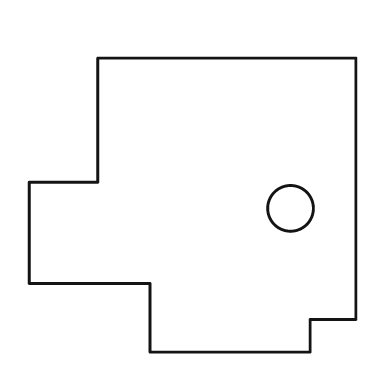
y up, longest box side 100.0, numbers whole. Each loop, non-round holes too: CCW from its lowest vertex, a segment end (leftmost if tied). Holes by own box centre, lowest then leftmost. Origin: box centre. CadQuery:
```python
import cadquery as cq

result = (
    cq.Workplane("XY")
    .moveTo(-13.0, -45.0)
    .lineTo(36.0, -45.0)
    .lineTo(36.0, -35.0)
    .lineTo(50.0, -35.0)
    .lineTo(50.0, 45.0)
    .lineTo(-29.0, 45.0)
    .lineTo(-29.0, 7.0)
    .lineTo(-50.0, 7.0)
    .lineTo(-50.0, -24.0)
    .lineTo(-13.0, -24.0)
    .close()
    .moveTo(30.0, -1.0)
    .circle(7.0)
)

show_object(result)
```